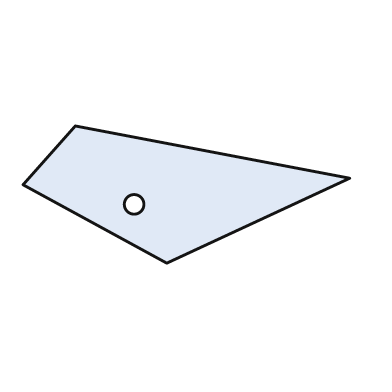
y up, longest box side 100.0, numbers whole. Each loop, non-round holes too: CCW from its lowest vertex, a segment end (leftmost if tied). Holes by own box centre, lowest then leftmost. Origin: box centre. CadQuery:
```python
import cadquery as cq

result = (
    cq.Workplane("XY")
    .moveTo(-6.0, -21.0)
    .lineTo(50.0, 5.0)
    .lineTo(-34.0, 21.0)
    .lineTo(-50.0, 3.0)
    .close()
    .moveTo(-16.0, -3.0)
    .circle(3.0)
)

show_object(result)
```